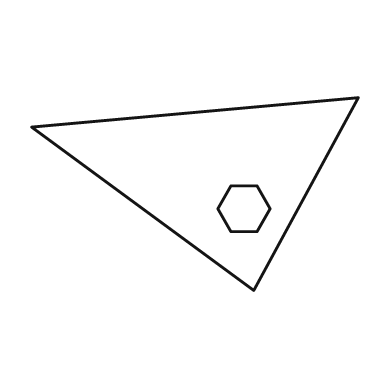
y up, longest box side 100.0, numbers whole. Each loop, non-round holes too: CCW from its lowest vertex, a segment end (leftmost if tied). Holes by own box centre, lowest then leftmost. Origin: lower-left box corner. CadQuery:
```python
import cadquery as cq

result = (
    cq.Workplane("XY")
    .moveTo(68.0, 0.0)
    .lineTo(100.0, 59.0)
    .lineTo(0.0, 50.0)
    .close()
    .moveTo(61.0, 18.0)
    .lineTo(69.0, 18.0)
    .lineTo(73.0, 25.0)
    .lineTo(69.0, 32.0)
    .lineTo(61.0, 32.0)
    .lineTo(57.0, 25.0)
    .close()
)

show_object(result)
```